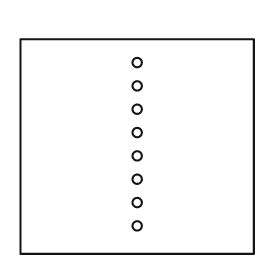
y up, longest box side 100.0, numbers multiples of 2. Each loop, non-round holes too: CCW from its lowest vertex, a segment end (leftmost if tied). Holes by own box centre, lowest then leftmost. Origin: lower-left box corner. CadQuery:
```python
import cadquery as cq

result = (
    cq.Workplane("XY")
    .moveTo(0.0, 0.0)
    .lineTo(100.0, 0.0)
    .lineTo(100.0, 92.0)
    .lineTo(0.0, 92.0)
    .close()
    .moveTo(50.0, 12.0)
    .circle(2.0)
    .moveTo(50.0, 22.0)
    .circle(2.0)
    .moveTo(50.0, 32.0)
    .circle(2.0)
    .moveTo(50.0, 42.0)
    .circle(2.0)
    .moveTo(50.0, 52.0)
    .circle(2.0)
    .moveTo(50.0, 62.0)
    .circle(2.0)
    .moveTo(50.0, 72.0)
    .circle(2.0)
    .moveTo(50.0, 82.0)
    .circle(2.0)
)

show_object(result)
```